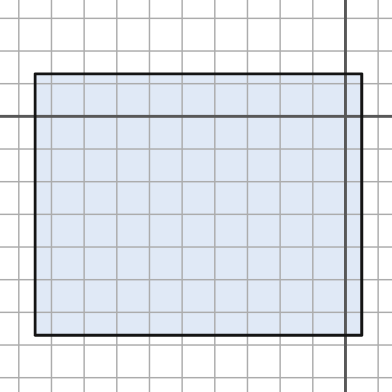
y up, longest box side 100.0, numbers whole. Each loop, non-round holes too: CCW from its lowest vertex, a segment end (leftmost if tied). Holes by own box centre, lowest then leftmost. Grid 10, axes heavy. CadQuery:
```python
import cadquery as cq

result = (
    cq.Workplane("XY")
    .moveTo(-95.0, -67.0)
    .lineTo(5.0, -67.0)
    .lineTo(5.0, 13.0)
    .lineTo(-95.0, 13.0)
    .close()
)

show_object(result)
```